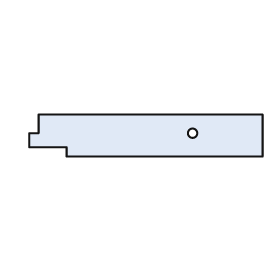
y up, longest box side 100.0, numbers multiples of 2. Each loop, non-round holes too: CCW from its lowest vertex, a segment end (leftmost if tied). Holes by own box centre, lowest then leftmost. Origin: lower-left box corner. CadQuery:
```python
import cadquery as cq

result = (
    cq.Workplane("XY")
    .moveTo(16.0, 0.0)
    .lineTo(100.0, 0.0)
    .lineTo(100.0, 18.0)
    .lineTo(4.0, 18.0)
    .lineTo(4.0, 10.0)
    .lineTo(0.0, 10.0)
    .lineTo(0.0, 4.0)
    .lineTo(16.0, 4.0)
    .close()
    .moveTo(70.0, 10.0)
    .circle(2.0)
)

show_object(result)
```